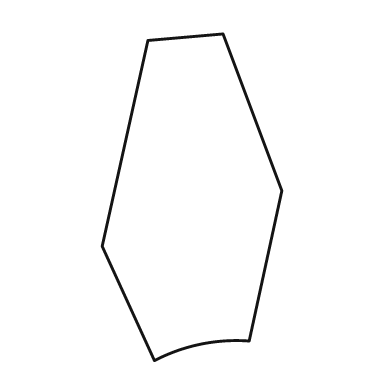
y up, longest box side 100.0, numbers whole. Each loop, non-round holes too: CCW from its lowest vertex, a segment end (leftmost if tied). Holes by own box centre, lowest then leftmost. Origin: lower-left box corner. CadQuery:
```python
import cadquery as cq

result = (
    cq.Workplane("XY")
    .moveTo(16.0, 0.0)
    .threePointArc((30.0, 5.0), (45.0, 6.0))
    .lineTo(55.0, 52.0)
    .lineTo(37.0, 100.0)
    .lineTo(14.0, 98.0)
    .lineTo(0.0, 35.0)
    .close()
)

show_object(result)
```